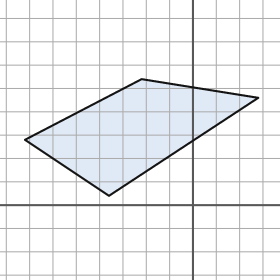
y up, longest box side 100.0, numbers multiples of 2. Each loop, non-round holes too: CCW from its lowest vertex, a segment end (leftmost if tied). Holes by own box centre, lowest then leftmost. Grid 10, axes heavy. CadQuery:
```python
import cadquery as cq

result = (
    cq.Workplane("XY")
    .moveTo(-36.0, 4.0)
    .lineTo(28.0, 46.0)
    .lineTo(-22.0, 54.0)
    .lineTo(-72.0, 28.0)
    .close()
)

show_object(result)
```